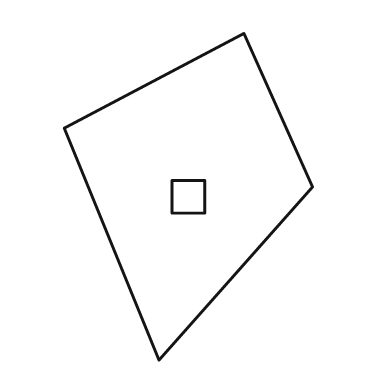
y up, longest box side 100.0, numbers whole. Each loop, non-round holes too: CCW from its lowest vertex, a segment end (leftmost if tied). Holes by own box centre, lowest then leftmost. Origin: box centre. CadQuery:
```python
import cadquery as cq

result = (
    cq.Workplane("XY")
    .moveTo(-9.0, -50.0)
    .lineTo(38.0, 3.0)
    .lineTo(17.0, 50.0)
    .lineTo(-38.0, 21.0)
    .close()
    .moveTo(-5.0, -5.0)
    .lineTo(5.0, -5.0)
    .lineTo(5.0, 5.0)
    .lineTo(-5.0, 5.0)
    .close()
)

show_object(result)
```